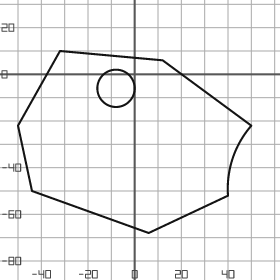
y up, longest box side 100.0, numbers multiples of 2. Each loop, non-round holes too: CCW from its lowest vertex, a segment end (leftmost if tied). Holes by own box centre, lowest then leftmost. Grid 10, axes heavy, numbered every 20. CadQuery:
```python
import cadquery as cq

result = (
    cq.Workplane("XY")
    .moveTo(6.0, -68.0)
    .lineTo(40.0, -52.0)
    .threePointArc((42.0, -36.0), (50.0, -22.0))
    .lineTo(12.0, 6.0)
    .lineTo(-32.0, 10.0)
    .lineTo(-50.0, -22.0)
    .lineTo(-44.0, -50.0)
    .close()
    .moveTo(-8.0, -6.0)
    .circle(8.0)
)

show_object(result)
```